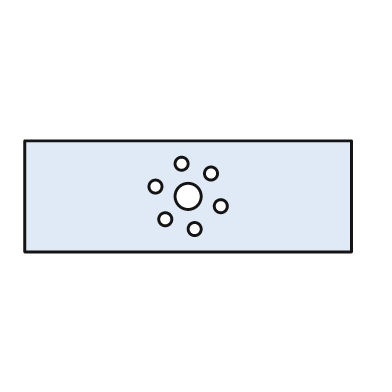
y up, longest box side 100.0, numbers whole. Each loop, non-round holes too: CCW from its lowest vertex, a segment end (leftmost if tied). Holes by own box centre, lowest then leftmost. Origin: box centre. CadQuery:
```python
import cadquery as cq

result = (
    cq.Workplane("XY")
    .moveTo(-50.0, -17.0)
    .lineTo(50.0, -17.0)
    .lineTo(50.0, 17.0)
    .lineTo(-50.0, 17.0)
    .close()
    .moveTo(2.0, -10.0)
    .circle(2.0)
    .moveTo(-7.0, -7.0)
    .circle(2.0)
    .moveTo(10.0, -3.0)
    .circle(2.0)
    .moveTo(0.0, 0.0)
    .circle(4.0)
    .moveTo(-10.0, 3.0)
    .circle(2.0)
    .moveTo(7.0, 7.0)
    .circle(2.0)
    .moveTo(-2.0, 10.0)
    .circle(2.0)
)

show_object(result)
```